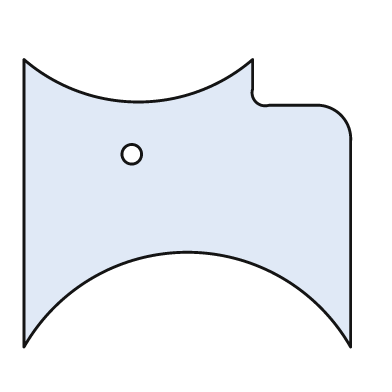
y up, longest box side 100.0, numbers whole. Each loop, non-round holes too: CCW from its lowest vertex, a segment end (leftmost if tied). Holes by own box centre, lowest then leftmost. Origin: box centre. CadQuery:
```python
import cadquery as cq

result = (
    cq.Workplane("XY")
    .moveTo(-50.0, -44.0)
    .threePointArc((0.0, -15.0), (50.0, -44.0))
    .lineTo(50.0, 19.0)
    .threePointArc((47.0, 27.0), (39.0, 30.0))
    .lineTo(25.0, 30.0)
    .threePointArc((21.0, 31.0), (20.0, 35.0))
    .lineTo(20.0, 44.0)
    .threePointArc((-15.0, 31.0), (-50.0, 44.0))
    .close()
    .moveTo(-17.0, 15.0)
    .circle(3.0)
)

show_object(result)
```